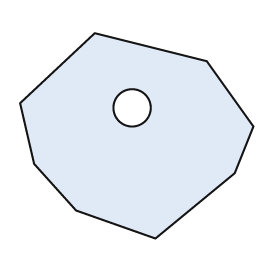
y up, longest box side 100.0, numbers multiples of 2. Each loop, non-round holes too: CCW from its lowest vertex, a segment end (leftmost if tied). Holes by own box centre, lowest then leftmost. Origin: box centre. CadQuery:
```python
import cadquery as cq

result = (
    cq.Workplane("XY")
    .moveTo(8.0, -44.0)
    .lineTo(42.0, -16.0)
    .lineTo(50.0, 4.0)
    .lineTo(30.0, 32.0)
    .lineTo(-18.0, 44.0)
    .lineTo(-50.0, 14.0)
    .lineTo(-44.0, -12.0)
    .lineTo(-26.0, -32.0)
    .close()
    .moveTo(-2.0, 12.0)
    .circle(8.0)
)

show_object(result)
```